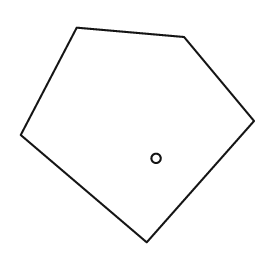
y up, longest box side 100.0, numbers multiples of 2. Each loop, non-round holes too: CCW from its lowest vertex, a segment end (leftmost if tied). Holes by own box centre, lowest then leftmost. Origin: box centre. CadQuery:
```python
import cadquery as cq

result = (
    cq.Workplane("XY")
    .moveTo(4.0, -46.0)
    .lineTo(50.0, 6.0)
    .lineTo(20.0, 42.0)
    .lineTo(-26.0, 46.0)
    .lineTo(-50.0, 0.0)
    .close()
    .moveTo(8.0, -10.0)
    .circle(2.0)
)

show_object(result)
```